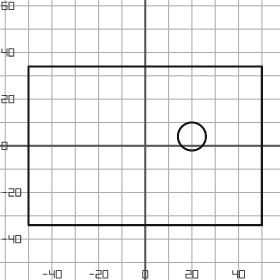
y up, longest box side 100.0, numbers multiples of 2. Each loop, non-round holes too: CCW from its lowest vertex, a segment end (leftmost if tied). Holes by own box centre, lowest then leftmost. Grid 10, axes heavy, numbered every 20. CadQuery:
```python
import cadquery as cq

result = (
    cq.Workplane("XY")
    .moveTo(-50.0, -34.0)
    .lineTo(50.0, -34.0)
    .lineTo(50.0, 34.0)
    .lineTo(-50.0, 34.0)
    .close()
    .moveTo(20.0, 4.0)
    .circle(6.0)
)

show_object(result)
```